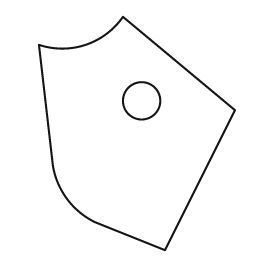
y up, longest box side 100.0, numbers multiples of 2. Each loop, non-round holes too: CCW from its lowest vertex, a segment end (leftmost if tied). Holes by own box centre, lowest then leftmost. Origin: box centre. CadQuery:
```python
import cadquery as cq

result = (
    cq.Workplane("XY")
    .moveTo(12.0, -50.0)
    .lineTo(42.0, 10.0)
    .lineTo(-6.0, 50.0)
    .threePointArc((-22.0, 38.0), (-42.0, 38.0))
    .lineTo(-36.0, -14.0)
    .threePointArc((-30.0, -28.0), (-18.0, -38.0))
    .close()
    .moveTo(2.0, 14.0)
    .circle(8.0)
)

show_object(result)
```